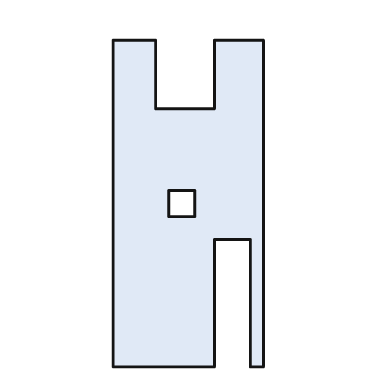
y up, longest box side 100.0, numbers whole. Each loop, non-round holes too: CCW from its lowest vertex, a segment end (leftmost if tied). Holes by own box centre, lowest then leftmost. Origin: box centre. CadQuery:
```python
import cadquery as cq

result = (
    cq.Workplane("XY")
    .moveTo(-23.0, -50.0)
    .lineTo(8.0, -50.0)
    .lineTo(8.0, -11.0)
    .lineTo(19.0, -11.0)
    .lineTo(19.0, -50.0)
    .lineTo(23.0, -50.0)
    .lineTo(23.0, 50.0)
    .lineTo(8.0, 50.0)
    .lineTo(8.0, 29.0)
    .lineTo(-10.0, 29.0)
    .lineTo(-10.0, 50.0)
    .lineTo(-23.0, 50.0)
    .close()
    .moveTo(-6.0, -4.0)
    .lineTo(2.0, -4.0)
    .lineTo(2.0, 4.0)
    .lineTo(-6.0, 4.0)
    .close()
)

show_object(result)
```